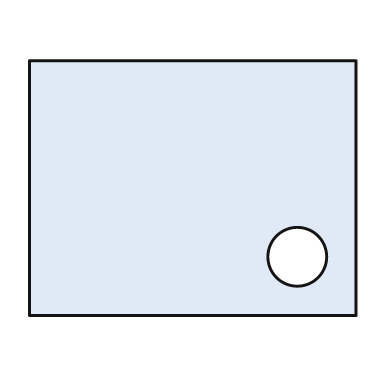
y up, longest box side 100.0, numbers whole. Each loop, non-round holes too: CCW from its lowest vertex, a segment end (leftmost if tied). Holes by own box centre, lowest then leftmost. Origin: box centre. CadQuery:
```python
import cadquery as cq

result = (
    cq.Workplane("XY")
    .moveTo(-50.0, -39.0)
    .lineTo(50.0, -39.0)
    .lineTo(50.0, 39.0)
    .lineTo(-50.0, 39.0)
    .close()
    .moveTo(32.0, -21.0)
    .circle(9.0)
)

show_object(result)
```